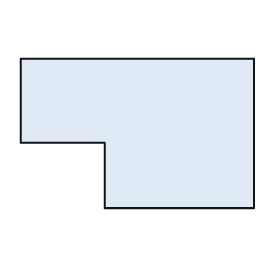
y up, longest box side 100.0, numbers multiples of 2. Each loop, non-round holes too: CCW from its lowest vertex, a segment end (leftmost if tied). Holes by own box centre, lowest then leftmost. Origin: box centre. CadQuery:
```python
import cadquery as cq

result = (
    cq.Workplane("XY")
    .moveTo(-14.0, -32.0)
    .lineTo(50.0, -32.0)
    .lineTo(50.0, 32.0)
    .lineTo(-50.0, 32.0)
    .lineTo(-50.0, -4.0)
    .lineTo(-14.0, -4.0)
    .close()
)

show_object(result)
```